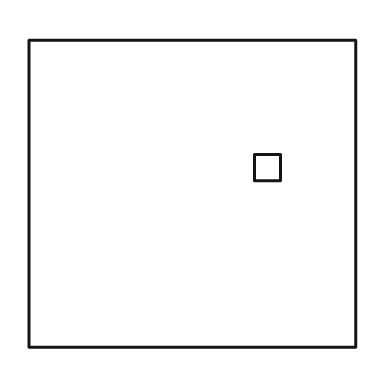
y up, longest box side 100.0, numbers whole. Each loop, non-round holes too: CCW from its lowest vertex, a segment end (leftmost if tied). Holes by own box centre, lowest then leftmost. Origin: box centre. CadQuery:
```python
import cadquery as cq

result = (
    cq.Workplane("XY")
    .moveTo(-50.0, -47.0)
    .lineTo(50.0, -47.0)
    .lineTo(50.0, 47.0)
    .lineTo(-50.0, 47.0)
    .close()
    .moveTo(19.0, 4.0)
    .lineTo(27.0, 4.0)
    .lineTo(27.0, 12.0)
    .lineTo(19.0, 12.0)
    .close()
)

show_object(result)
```